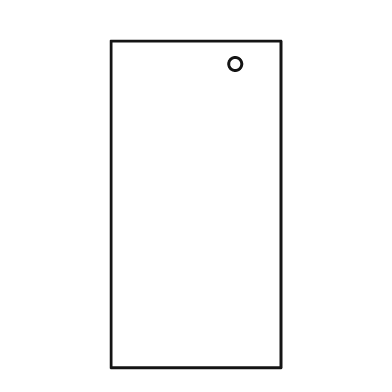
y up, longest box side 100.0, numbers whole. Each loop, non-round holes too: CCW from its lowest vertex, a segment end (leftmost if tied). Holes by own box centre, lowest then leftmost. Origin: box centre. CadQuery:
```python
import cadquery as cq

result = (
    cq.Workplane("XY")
    .moveTo(-26.0, -50.0)
    .lineTo(26.0, -50.0)
    .lineTo(26.0, 50.0)
    .lineTo(-26.0, 50.0)
    .close()
    .moveTo(12.0, 43.0)
    .circle(2.0)
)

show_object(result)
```